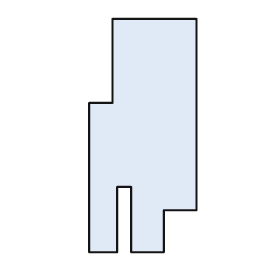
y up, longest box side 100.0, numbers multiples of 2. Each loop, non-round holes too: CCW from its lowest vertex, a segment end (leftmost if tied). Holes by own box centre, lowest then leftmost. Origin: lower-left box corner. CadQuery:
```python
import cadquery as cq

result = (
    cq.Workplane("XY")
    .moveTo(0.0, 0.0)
    .lineTo(12.0, 0.0)
    .lineTo(12.0, 28.0)
    .lineTo(18.0, 28.0)
    .lineTo(18.0, 0.0)
    .lineTo(32.0, 0.0)
    .lineTo(32.0, 18.0)
    .lineTo(46.0, 18.0)
    .lineTo(46.0, 100.0)
    .lineTo(10.0, 100.0)
    .lineTo(10.0, 64.0)
    .lineTo(0.0, 64.0)
    .close()
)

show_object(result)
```